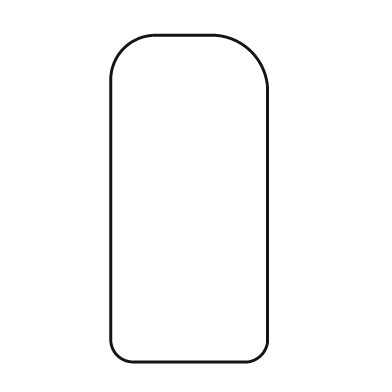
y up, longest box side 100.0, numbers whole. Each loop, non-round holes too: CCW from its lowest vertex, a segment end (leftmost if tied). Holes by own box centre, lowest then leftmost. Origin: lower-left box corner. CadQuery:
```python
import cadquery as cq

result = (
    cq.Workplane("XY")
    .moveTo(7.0, 0.0)
    .lineTo(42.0, 0.0)
    .threePointArc((46.0, 2.0), (48.0, 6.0))
    .lineTo(48.0, 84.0)
    .threePointArc((43.0, 95.0), (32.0, 100.0))
    .lineTo(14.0, 100.0)
    .threePointArc((4.0, 96.0), (0.0, 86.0))
    .lineTo(0.0, 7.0)
    .threePointArc((2.0, 2.0), (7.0, 0.0))
    .close()
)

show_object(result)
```